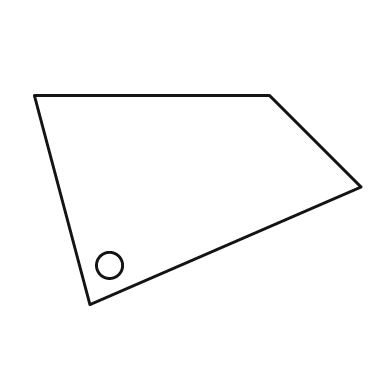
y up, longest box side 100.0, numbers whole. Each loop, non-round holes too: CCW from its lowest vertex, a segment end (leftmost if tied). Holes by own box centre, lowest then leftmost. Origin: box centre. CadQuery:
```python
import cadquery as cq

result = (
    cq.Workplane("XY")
    .moveTo(-33.0, -32.0)
    .lineTo(50.0, 4.0)
    .lineTo(22.0, 32.0)
    .lineTo(-50.0, 32.0)
    .close()
    .moveTo(-27.0, -20.0)
    .circle(4.0)
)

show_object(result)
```